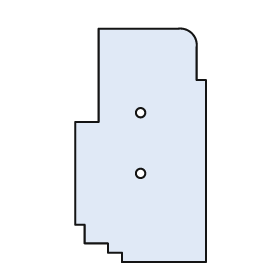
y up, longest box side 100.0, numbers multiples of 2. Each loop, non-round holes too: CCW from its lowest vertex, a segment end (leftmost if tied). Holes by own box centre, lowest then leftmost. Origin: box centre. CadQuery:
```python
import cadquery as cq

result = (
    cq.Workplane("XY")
    .moveTo(-8.0, -50.0)
    .lineTo(28.0, -50.0)
    .lineTo(28.0, 28.0)
    .lineTo(24.0, 28.0)
    .lineTo(24.0, 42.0)
    .threePointArc((22.0, 48.0), (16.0, 50.0))
    .lineTo(-18.0, 50.0)
    .lineTo(-18.0, 10.0)
    .lineTo(-28.0, 10.0)
    .lineTo(-28.0, -34.0)
    .lineTo(-24.0, -34.0)
    .lineTo(-24.0, -42.0)
    .lineTo(-14.0, -42.0)
    .lineTo(-14.0, -46.0)
    .lineTo(-8.0, -46.0)
    .close()
    .moveTo(0.0, -12.0)
    .circle(2.0)
    .moveTo(0.0, 14.0)
    .circle(2.0)
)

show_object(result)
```